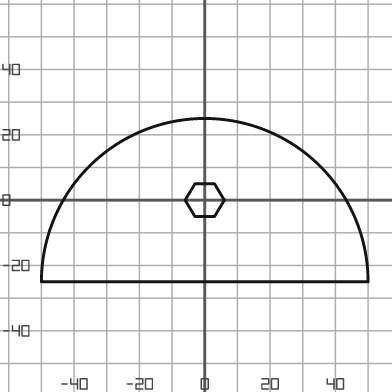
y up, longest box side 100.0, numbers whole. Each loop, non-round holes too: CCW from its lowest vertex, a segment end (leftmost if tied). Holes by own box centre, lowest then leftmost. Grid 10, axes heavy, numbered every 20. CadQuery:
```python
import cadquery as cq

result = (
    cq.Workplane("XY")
    .moveTo(-50.0, -25.0)
    .lineTo(50.0, -25.0)
    .threePointArc((0.0, 25.0), (-50.0, -25.0))
    .close()
    .moveTo(-3.0, -5.0)
    .lineTo(3.0, -5.0)
    .lineTo(6.0, 0.0)
    .lineTo(3.0, 5.0)
    .lineTo(-3.0, 5.0)
    .lineTo(-6.0, 0.0)
    .close()
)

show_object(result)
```